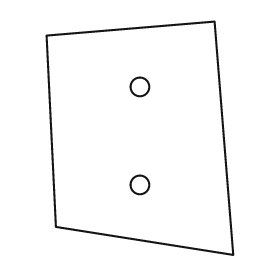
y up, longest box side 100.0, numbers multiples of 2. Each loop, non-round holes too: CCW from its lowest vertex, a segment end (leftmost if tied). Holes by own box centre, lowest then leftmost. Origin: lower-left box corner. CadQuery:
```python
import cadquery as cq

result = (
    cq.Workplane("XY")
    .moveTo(80.0, 0.0)
    .lineTo(72.0, 100.0)
    .lineTo(0.0, 94.0)
    .lineTo(4.0, 12.0)
    .close()
    .moveTo(40.0, 30.0)
    .circle(4.0)
    .moveTo(40.0, 72.0)
    .circle(4.0)
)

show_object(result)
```